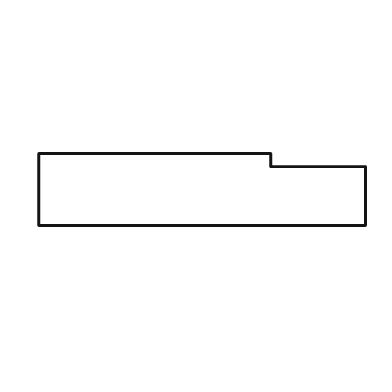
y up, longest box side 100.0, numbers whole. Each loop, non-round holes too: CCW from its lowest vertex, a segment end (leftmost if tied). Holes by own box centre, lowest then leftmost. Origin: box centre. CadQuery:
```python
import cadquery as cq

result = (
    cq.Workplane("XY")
    .moveTo(-50.0, -11.0)
    .lineTo(50.0, -11.0)
    .lineTo(50.0, 7.0)
    .lineTo(21.0, 7.0)
    .lineTo(21.0, 11.0)
    .lineTo(-50.0, 11.0)
    .close()
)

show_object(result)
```